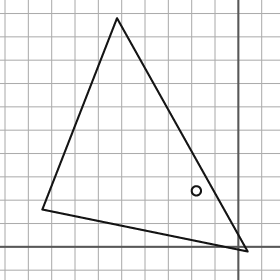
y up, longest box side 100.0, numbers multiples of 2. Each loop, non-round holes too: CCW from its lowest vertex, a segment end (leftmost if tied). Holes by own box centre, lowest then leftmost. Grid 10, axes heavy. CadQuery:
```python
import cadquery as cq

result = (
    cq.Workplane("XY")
    .moveTo(4.0, -2.0)
    .lineTo(-52.0, 98.0)
    .lineTo(-84.0, 16.0)
    .close()
    .moveTo(-18.0, 24.0)
    .circle(2.0)
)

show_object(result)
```